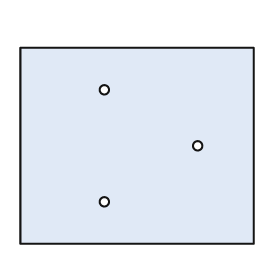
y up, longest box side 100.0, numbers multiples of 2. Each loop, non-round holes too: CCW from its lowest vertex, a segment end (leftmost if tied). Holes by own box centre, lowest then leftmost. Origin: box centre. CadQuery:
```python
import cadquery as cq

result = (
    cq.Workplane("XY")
    .moveTo(-50.0, -42.0)
    .lineTo(50.0, -42.0)
    .lineTo(50.0, 42.0)
    .lineTo(-50.0, 42.0)
    .close()
    .moveTo(-14.0, -24.0)
    .circle(2.0)
    .moveTo(26.0, 0.0)
    .circle(2.0)
    .moveTo(-14.0, 24.0)
    .circle(2.0)
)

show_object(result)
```